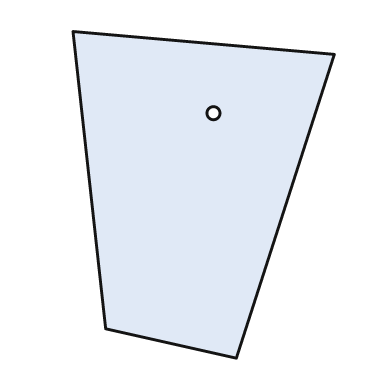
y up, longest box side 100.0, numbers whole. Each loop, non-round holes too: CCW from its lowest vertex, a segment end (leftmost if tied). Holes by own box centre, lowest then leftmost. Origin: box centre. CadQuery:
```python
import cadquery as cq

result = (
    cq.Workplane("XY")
    .moveTo(10.0, -50.0)
    .lineTo(40.0, 43.0)
    .lineTo(-40.0, 50.0)
    .lineTo(-30.0, -41.0)
    .close()
    .moveTo(3.0, 25.0)
    .circle(2.0)
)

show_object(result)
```